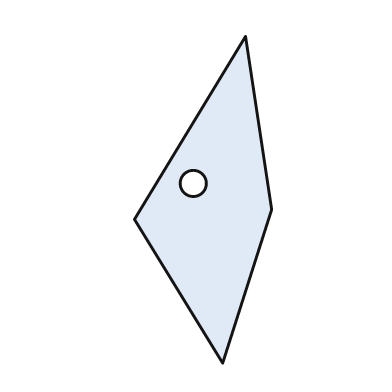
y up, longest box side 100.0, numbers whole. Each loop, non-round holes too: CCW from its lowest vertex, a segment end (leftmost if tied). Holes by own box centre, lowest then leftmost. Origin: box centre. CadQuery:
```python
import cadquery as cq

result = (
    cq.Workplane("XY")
    .moveTo(6.0, -50.0)
    .lineTo(21.0, -3.0)
    .lineTo(13.0, 50.0)
    .lineTo(-21.0, -6.0)
    .close()
    .moveTo(-3.0, 5.0)
    .circle(4.0)
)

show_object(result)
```